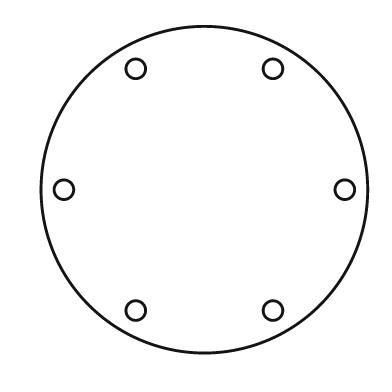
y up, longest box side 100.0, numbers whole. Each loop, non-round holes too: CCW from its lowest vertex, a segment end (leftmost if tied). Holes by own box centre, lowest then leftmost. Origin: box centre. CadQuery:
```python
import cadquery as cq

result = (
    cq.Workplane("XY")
    .moveTo(0.0, 0.0)
    .circle(50.0)
    .moveTo(-21.0, -37.0)
    .circle(3.0)
    .moveTo(21.0, -37.0)
    .circle(3.0)
    .moveTo(-43.0, 0.0)
    .circle(3.0)
    .moveTo(43.0, 0.0)
    .circle(3.0)
    .moveTo(-21.0, 37.0)
    .circle(3.0)
    .moveTo(21.0, 37.0)
    .circle(3.0)
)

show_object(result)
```